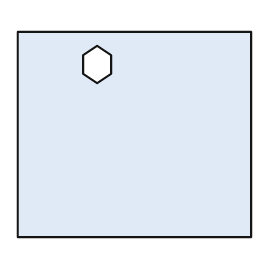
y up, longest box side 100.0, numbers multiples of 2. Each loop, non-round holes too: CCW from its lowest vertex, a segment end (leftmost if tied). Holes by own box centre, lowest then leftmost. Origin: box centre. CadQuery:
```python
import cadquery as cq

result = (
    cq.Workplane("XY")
    .moveTo(-50.0, -44.0)
    .lineTo(50.0, -44.0)
    .lineTo(50.0, 44.0)
    .lineTo(-50.0, 44.0)
    .close()
    .moveTo(-16.0, 22.0)
    .lineTo(-10.0, 26.0)
    .lineTo(-10.0, 34.0)
    .lineTo(-16.0, 38.0)
    .lineTo(-22.0, 34.0)
    .lineTo(-22.0, 26.0)
    .close()
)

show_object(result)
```